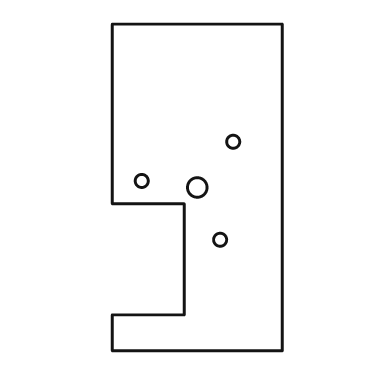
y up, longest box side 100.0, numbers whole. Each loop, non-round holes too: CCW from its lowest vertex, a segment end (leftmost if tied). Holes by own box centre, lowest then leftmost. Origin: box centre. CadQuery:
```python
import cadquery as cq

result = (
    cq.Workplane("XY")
    .moveTo(-26.0, -50.0)
    .lineTo(26.0, -50.0)
    .lineTo(26.0, 50.0)
    .lineTo(-26.0, 50.0)
    .lineTo(-26.0, -5.0)
    .lineTo(-4.0, -5.0)
    .lineTo(-4.0, -39.0)
    .lineTo(-26.0, -39.0)
    .close()
    .moveTo(7.0, -16.0)
    .circle(2.0)
    .moveTo(0.0, 0.0)
    .circle(3.0)
    .moveTo(-17.0, 2.0)
    .circle(2.0)
    .moveTo(11.0, 14.0)
    .circle(2.0)
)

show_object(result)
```